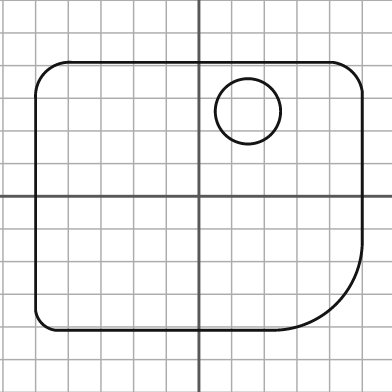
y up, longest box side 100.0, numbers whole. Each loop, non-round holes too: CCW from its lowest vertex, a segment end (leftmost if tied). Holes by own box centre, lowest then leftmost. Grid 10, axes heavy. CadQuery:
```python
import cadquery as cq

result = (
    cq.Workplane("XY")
    .moveTo(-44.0, -41.0)
    .lineTo(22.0, -41.0)
    .threePointArc((42.0, -33.0), (50.0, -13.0))
    .lineTo(50.0, 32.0)
    .threePointArc((47.0, 38.0), (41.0, 41.0))
    .lineTo(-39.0, 41.0)
    .threePointArc((-47.0, 38.0), (-50.0, 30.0))
    .lineTo(-50.0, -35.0)
    .threePointArc((-48.0, -39.0), (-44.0, -41.0))
    .close()
    .moveTo(15.0, 26.0)
    .circle(10.0)
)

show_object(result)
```